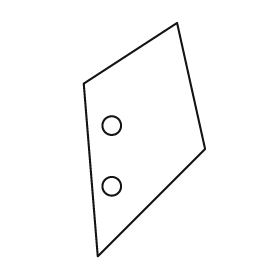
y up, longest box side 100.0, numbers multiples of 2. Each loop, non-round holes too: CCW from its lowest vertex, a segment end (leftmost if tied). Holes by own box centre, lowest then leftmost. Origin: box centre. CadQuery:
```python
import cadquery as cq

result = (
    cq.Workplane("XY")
    .moveTo(-20.0, -50.0)
    .lineTo(26.0, -4.0)
    .lineTo(14.0, 50.0)
    .lineTo(-26.0, 24.0)
    .close()
    .moveTo(-14.0, -20.0)
    .circle(4.0)
    .moveTo(-14.0, 6.0)
    .circle(4.0)
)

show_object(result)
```